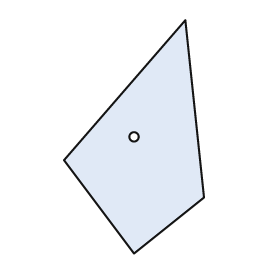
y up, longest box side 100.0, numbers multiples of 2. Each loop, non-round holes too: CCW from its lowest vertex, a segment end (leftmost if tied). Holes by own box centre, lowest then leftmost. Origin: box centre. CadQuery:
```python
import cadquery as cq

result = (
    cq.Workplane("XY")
    .moveTo(0.0, -50.0)
    .lineTo(30.0, -26.0)
    .lineTo(22.0, 50.0)
    .lineTo(-30.0, -10.0)
    .close()
    .moveTo(0.0, 0.0)
    .circle(2.0)
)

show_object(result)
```